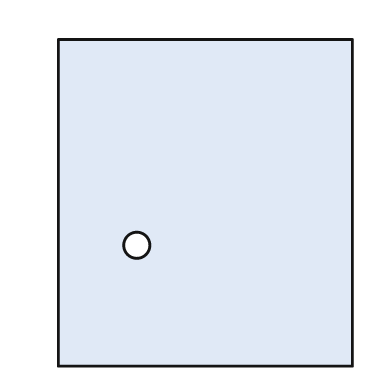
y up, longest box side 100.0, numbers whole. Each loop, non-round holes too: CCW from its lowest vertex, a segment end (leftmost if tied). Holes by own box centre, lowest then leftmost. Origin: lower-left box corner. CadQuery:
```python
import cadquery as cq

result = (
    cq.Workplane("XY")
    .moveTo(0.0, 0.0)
    .lineTo(90.0, 0.0)
    .lineTo(90.0, 100.0)
    .lineTo(0.0, 100.0)
    .close()
    .moveTo(24.0, 37.0)
    .circle(4.0)
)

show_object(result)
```